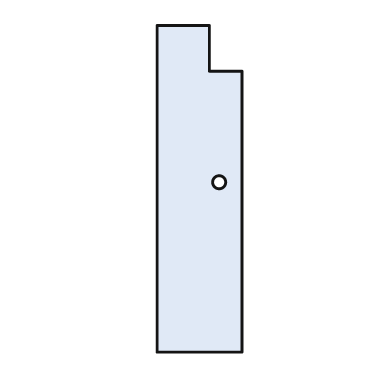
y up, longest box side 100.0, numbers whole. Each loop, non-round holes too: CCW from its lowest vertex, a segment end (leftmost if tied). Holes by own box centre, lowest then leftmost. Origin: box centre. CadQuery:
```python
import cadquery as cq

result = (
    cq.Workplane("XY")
    .moveTo(-13.0, -50.0)
    .lineTo(13.0, -50.0)
    .lineTo(13.0, 36.0)
    .lineTo(3.0, 36.0)
    .lineTo(3.0, 50.0)
    .lineTo(-13.0, 50.0)
    .close()
    .moveTo(6.0, 2.0)
    .circle(2.0)
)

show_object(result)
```